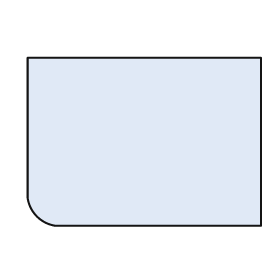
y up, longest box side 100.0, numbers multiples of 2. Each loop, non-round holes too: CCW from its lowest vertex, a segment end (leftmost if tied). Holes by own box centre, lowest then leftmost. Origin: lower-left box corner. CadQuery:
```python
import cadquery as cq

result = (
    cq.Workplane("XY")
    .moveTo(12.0, 0.0)
    .lineTo(100.0, 0.0)
    .lineTo(100.0, 72.0)
    .lineTo(0.0, 72.0)
    .lineTo(0.0, 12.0)
    .threePointArc((4.0, 4.0), (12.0, 0.0))
    .close()
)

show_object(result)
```